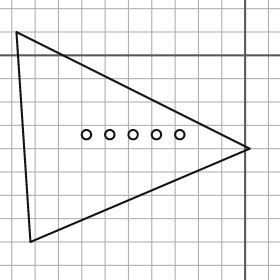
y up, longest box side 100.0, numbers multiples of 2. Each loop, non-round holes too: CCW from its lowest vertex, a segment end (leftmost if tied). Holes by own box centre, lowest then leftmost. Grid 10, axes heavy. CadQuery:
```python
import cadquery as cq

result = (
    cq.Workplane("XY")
    .moveTo(-92.0, -80.0)
    .lineTo(2.0, -40.0)
    .lineTo(-98.0, 10.0)
    .close()
    .moveTo(-68.0, -34.0)
    .circle(2.0)
    .moveTo(-58.0, -34.0)
    .circle(2.0)
    .moveTo(-48.0, -34.0)
    .circle(2.0)
    .moveTo(-38.0, -34.0)
    .circle(2.0)
    .moveTo(-28.0, -34.0)
    .circle(2.0)
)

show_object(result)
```